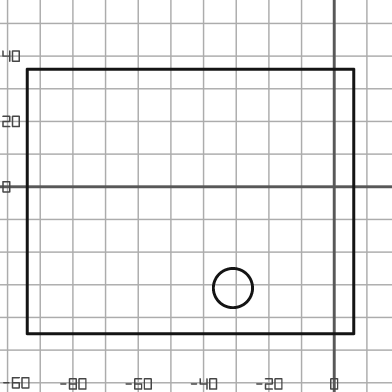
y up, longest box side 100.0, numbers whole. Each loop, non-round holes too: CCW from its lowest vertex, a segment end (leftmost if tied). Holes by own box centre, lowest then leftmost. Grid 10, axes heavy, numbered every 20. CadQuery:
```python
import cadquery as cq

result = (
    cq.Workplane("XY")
    .moveTo(-94.0, -45.0)
    .lineTo(6.0, -45.0)
    .lineTo(6.0, 36.0)
    .lineTo(-94.0, 36.0)
    .close()
    .moveTo(-31.0, -31.0)
    .circle(6.0)
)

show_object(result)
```